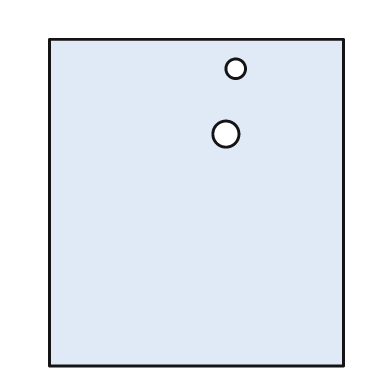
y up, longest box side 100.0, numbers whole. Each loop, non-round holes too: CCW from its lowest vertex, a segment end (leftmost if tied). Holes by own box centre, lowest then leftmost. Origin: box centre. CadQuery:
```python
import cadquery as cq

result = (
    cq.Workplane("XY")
    .moveTo(-45.0, -50.0)
    .lineTo(45.0, -50.0)
    .lineTo(45.0, 50.0)
    .lineTo(-45.0, 50.0)
    .close()
    .moveTo(9.0, 21.0)
    .circle(4.0)
    .moveTo(12.0, 41.0)
    .circle(3.0)
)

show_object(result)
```